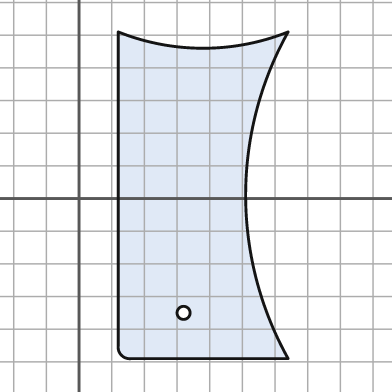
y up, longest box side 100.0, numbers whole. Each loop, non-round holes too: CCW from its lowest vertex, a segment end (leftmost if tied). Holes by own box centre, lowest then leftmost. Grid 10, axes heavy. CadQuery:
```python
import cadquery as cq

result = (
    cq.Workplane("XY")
    .moveTo(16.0, -49.0)
    .lineTo(64.0, -49.0)
    .threePointArc((51.0, 1.0), (64.0, 51.0))
    .threePointArc((38.0, 46.0), (12.0, 51.0))
    .lineTo(12.0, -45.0)
    .threePointArc((13.0, -48.0), (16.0, -49.0))
    .close()
    .moveTo(32.0, -35.0)
    .circle(2.0)
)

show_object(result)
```